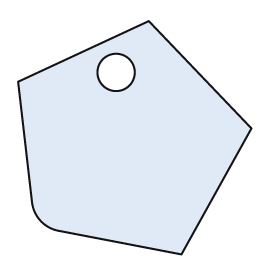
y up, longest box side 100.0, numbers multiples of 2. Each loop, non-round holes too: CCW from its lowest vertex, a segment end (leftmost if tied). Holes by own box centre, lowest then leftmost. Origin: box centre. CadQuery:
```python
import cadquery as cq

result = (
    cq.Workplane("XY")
    .moveTo(20.0, -50.0)
    .lineTo(50.0, 4.0)
    .lineTo(6.0, 50.0)
    .lineTo(-50.0, 24.0)
    .lineTo(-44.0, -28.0)
    .threePointArc((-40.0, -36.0), (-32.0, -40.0))
    .close()
    .moveTo(-8.0, 28.0)
    .circle(8.0)
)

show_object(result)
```